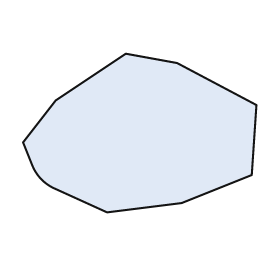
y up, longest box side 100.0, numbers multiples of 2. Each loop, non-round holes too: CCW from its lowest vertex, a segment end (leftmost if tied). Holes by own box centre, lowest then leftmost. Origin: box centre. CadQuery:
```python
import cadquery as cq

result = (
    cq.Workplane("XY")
    .moveTo(-14.0, -34.0)
    .lineTo(18.0, -30.0)
    .lineTo(48.0, -18.0)
    .lineTo(50.0, 12.0)
    .lineTo(16.0, 30.0)
    .lineTo(-6.0, 34.0)
    .lineTo(-36.0, 14.0)
    .lineTo(-50.0, -4.0)
    .lineTo(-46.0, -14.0)
    .threePointArc((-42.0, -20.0), (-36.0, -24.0))
    .close()
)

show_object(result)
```